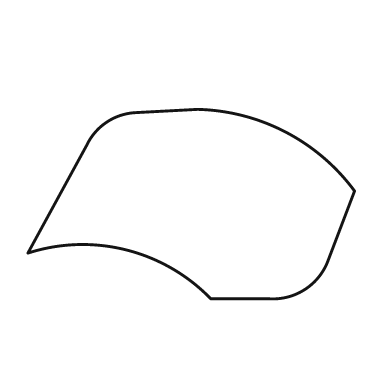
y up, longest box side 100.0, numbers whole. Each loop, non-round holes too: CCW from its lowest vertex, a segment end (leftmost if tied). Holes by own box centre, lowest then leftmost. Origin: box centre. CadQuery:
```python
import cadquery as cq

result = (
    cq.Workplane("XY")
    .moveTo(6.0, -29.0)
    .lineTo(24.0, -29.0)
    .threePointArc((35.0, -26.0), (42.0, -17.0))
    .lineTo(50.0, 4.0)
    .threePointArc((29.0, 22.0), (2.0, 29.0))
    .lineTo(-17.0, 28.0)
    .threePointArc((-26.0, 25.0), (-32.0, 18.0))
    .lineTo(-50.0, -15.0)
    .threePointArc((-20.0, -14.0), (6.0, -29.0))
    .close()
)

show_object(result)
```